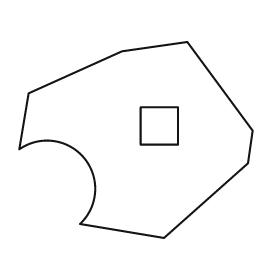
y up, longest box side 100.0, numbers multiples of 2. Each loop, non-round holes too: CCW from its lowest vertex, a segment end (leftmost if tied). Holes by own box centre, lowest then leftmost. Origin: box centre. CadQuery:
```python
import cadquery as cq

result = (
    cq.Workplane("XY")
    .moveTo(12.0, -42.0)
    .lineTo(48.0, -10.0)
    .lineTo(50.0, 4.0)
    .lineTo(22.0, 42.0)
    .lineTo(-6.0, 38.0)
    .lineTo(-46.0, 20.0)
    .lineTo(-50.0, -4.0)
    .threePointArc((-22.0, -8.0), (-24.0, -36.0))
    .close()
    .moveTo(2.0, -2.0)
    .lineTo(18.0, -2.0)
    .lineTo(18.0, 14.0)
    .lineTo(2.0, 14.0)
    .close()
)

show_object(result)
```